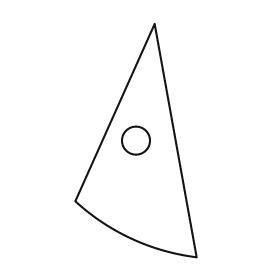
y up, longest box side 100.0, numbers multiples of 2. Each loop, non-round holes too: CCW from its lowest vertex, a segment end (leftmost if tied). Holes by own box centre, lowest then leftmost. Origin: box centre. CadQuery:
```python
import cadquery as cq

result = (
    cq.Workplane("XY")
    .moveTo(26.0, -50.0)
    .lineTo(8.0, 50.0)
    .lineTo(-26.0, -26.0)
    .threePointArc((-2.0, -42.0), (26.0, -50.0))
    .close()
    .moveTo(0.0, 0.0)
    .circle(6.0)
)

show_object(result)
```